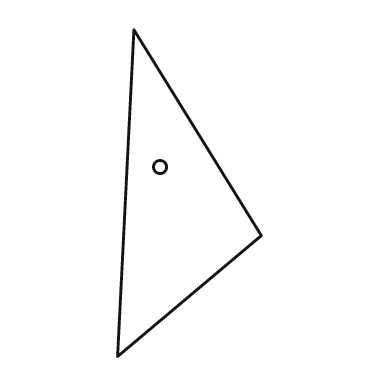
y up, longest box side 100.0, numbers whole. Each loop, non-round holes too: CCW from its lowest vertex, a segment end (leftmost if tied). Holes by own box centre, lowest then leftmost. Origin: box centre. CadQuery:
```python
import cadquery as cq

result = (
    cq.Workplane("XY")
    .moveTo(-22.0, -50.0)
    .lineTo(22.0, -13.0)
    .lineTo(-17.0, 50.0)
    .close()
    .moveTo(-9.0, 8.0)
    .circle(2.0)
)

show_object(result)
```